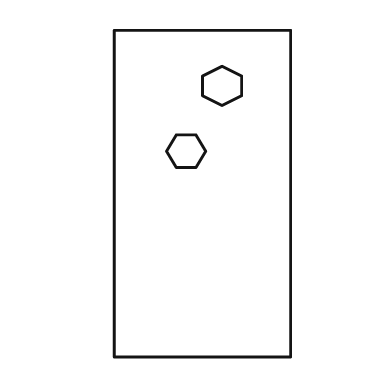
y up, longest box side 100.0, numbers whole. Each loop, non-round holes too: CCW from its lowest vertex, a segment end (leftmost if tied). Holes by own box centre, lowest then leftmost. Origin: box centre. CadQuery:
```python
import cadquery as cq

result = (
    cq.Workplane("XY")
    .moveTo(-27.0, -50.0)
    .lineTo(27.0, -50.0)
    .lineTo(27.0, 50.0)
    .lineTo(-27.0, 50.0)
    .close()
    .moveTo(-8.0, 8.0)
    .lineTo(-2.0, 8.0)
    .lineTo(1.0, 13.0)
    .lineTo(-2.0, 18.0)
    .lineTo(-8.0, 18.0)
    .lineTo(-11.0, 13.0)
    .close()
    .moveTo(6.0, 27.0)
    .lineTo(12.0, 30.0)
    .lineTo(12.0, 36.0)
    .lineTo(6.0, 39.0)
    .lineTo(0.0, 36.0)
    .lineTo(0.0, 30.0)
    .close()
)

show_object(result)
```